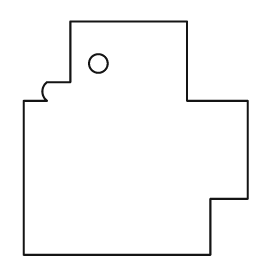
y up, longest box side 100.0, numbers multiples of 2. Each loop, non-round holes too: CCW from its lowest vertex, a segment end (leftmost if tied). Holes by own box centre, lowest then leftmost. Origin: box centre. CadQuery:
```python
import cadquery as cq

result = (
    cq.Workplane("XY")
    .moveTo(-48.0, -50.0)
    .lineTo(32.0, -50.0)
    .lineTo(32.0, -26.0)
    .lineTo(48.0, -26.0)
    .lineTo(48.0, 16.0)
    .lineTo(22.0, 16.0)
    .lineTo(22.0, 50.0)
    .lineTo(-28.0, 50.0)
    .lineTo(-28.0, 24.0)
    .lineTo(-38.0, 24.0)
    .threePointArc((-40.0, 20.0), (-38.0, 16.0))
    .lineTo(-48.0, 16.0)
    .close()
    .moveTo(-16.0, 32.0)
    .circle(4.0)
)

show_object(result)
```